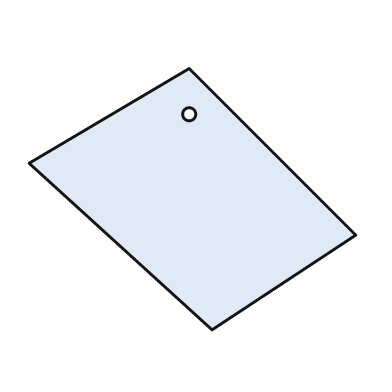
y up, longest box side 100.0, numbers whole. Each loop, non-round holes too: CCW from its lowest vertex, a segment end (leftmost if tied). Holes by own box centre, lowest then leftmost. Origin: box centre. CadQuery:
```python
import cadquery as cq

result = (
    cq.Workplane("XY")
    .moveTo(6.0, -40.0)
    .lineTo(50.0, -11.0)
    .lineTo(-1.0, 40.0)
    .lineTo(-50.0, 11.0)
    .close()
    .moveTo(-1.0, 26.0)
    .circle(2.0)
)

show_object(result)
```